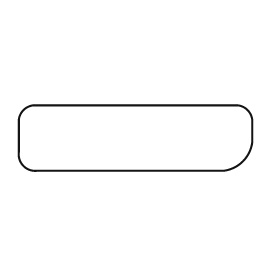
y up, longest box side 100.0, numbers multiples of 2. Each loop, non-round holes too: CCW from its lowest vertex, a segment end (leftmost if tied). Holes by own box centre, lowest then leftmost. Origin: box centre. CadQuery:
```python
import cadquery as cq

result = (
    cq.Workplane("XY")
    .moveTo(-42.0, -14.0)
    .lineTo(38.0, -14.0)
    .threePointArc((46.0, -10.0), (50.0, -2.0))
    .lineTo(50.0, 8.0)
    .threePointArc((48.0, 12.0), (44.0, 14.0))
    .lineTo(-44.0, 14.0)
    .threePointArc((-48.0, 12.0), (-50.0, 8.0))
    .lineTo(-50.0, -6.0)
    .threePointArc((-48.0, -12.0), (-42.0, -14.0))
    .close()
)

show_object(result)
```